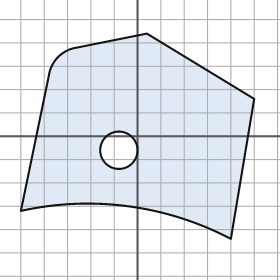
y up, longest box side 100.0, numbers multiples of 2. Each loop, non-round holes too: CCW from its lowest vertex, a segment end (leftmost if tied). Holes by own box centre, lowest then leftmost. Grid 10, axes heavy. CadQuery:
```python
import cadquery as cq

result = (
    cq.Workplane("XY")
    .moveTo(40.0, -44.0)
    .lineTo(50.0, 16.0)
    .lineTo(4.0, 44.0)
    .lineTo(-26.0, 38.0)
    .threePointArc((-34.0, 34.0), (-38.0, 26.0))
    .lineTo(-50.0, -32.0)
    .threePointArc((-4.0, -30.0), (40.0, -44.0))
    .close()
    .moveTo(-8.0, -6.0)
    .circle(8.0)
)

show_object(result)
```